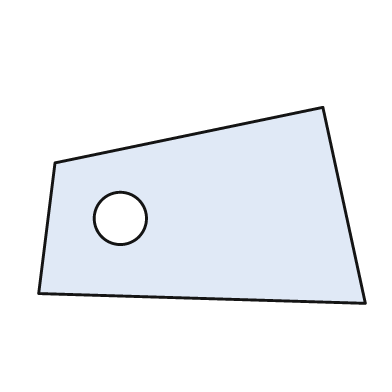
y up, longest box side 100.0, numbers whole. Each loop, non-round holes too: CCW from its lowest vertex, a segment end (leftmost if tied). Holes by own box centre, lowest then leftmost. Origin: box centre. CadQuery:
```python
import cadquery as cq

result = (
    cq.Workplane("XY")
    .moveTo(50.0, -30.0)
    .lineTo(37.0, 30.0)
    .lineTo(-45.0, 13.0)
    .lineTo(-50.0, -27.0)
    .close()
    .moveTo(-25.0, -4.0)
    .circle(8.0)
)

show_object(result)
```